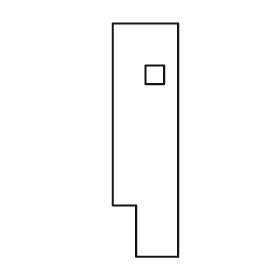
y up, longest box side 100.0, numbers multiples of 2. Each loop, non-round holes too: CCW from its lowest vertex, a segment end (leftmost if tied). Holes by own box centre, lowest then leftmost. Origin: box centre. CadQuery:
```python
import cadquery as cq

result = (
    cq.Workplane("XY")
    .moveTo(-4.0, -50.0)
    .lineTo(14.0, -50.0)
    .lineTo(14.0, 50.0)
    .lineTo(-14.0, 50.0)
    .lineTo(-14.0, -28.0)
    .lineTo(-4.0, -28.0)
    .close()
    .moveTo(0.0, 24.0)
    .lineTo(8.0, 24.0)
    .lineTo(8.0, 32.0)
    .lineTo(0.0, 32.0)
    .close()
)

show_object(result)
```